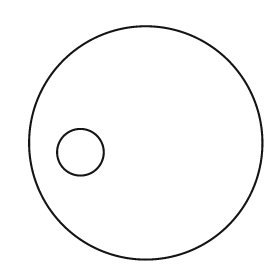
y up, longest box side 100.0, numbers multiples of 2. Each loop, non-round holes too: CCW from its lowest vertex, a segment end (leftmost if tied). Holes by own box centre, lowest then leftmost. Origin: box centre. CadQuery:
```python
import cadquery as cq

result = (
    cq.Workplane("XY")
    .moveTo(0.0, 0.0)
    .circle(50.0)
    .moveTo(-28.0, -4.0)
    .circle(10.0)
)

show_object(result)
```